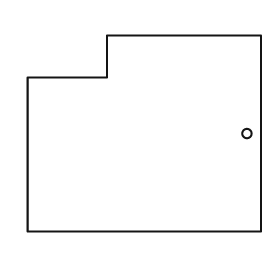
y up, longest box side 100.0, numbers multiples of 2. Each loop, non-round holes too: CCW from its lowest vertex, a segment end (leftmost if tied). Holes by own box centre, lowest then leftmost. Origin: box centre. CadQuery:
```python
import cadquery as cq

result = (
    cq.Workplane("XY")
    .moveTo(-50.0, -42.0)
    .lineTo(50.0, -42.0)
    .lineTo(50.0, 42.0)
    .lineTo(-16.0, 42.0)
    .lineTo(-16.0, 24.0)
    .lineTo(-50.0, 24.0)
    .close()
    .moveTo(44.0, 0.0)
    .circle(2.0)
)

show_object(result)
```